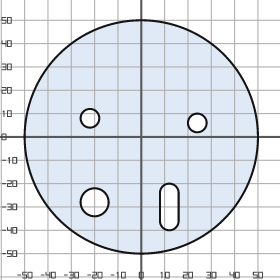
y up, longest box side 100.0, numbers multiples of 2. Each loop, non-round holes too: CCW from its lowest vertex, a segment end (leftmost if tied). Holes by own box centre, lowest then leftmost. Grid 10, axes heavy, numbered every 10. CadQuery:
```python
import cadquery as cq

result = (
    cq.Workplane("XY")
    .moveTo(0.0, 0.0)
    .circle(50.0)
    .moveTo(8.0, -36.0)
    .threePointArc((12.0, -40.0), (16.0, -36.0))
    .lineTo(16.0, -24.0)
    .threePointArc((12.0, -20.0), (8.0, -24.0))
    .close()
    .moveTo(-20.0, -28.0)
    .circle(6.0)
    .moveTo(24.0, 6.0)
    .circle(4.0)
    .moveTo(-22.0, 8.0)
    .circle(4.0)
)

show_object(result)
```